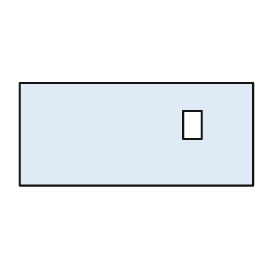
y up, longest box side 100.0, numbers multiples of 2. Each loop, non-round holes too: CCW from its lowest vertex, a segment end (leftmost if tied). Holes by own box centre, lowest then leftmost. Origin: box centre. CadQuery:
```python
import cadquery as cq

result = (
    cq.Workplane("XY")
    .moveTo(-50.0, -22.0)
    .lineTo(50.0, -22.0)
    .lineTo(50.0, 22.0)
    .lineTo(-50.0, 22.0)
    .close()
    .moveTo(20.0, -2.0)
    .lineTo(28.0, -2.0)
    .lineTo(28.0, 10.0)
    .lineTo(20.0, 10.0)
    .close()
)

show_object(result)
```